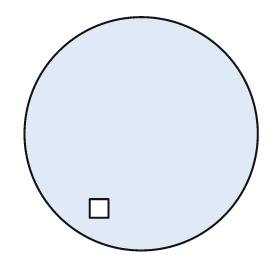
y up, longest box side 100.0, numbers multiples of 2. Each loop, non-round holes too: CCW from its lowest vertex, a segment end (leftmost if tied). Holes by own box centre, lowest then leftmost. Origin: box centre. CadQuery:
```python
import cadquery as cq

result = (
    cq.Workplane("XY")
    .moveTo(0.0, 0.0)
    .circle(50.0)
    .moveTo(-22.0, -36.0)
    .lineTo(-14.0, -36.0)
    .lineTo(-14.0, -28.0)
    .lineTo(-22.0, -28.0)
    .close()
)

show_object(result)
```